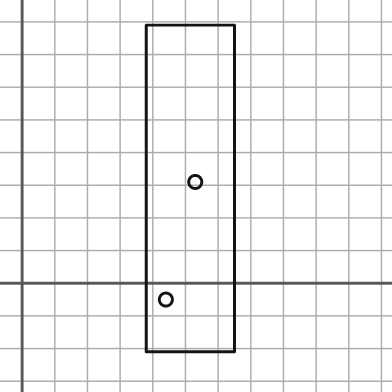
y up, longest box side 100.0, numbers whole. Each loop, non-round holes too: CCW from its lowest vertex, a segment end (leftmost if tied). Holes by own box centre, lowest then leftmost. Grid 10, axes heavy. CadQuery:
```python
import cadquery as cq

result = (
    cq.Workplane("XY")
    .moveTo(38.0, -21.0)
    .lineTo(65.0, -21.0)
    .lineTo(65.0, 79.0)
    .lineTo(38.0, 79.0)
    .close()
    .moveTo(44.0, -5.0)
    .circle(2.0)
    .moveTo(53.0, 31.0)
    .circle(2.0)
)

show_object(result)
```